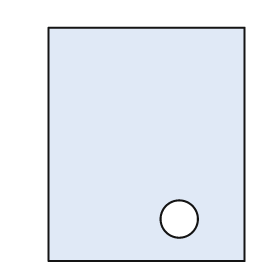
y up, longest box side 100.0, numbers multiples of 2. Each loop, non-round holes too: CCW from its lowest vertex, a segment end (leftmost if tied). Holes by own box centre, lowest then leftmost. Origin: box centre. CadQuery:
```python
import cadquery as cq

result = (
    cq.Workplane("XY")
    .moveTo(-42.0, -50.0)
    .lineTo(42.0, -50.0)
    .lineTo(42.0, 50.0)
    .lineTo(-42.0, 50.0)
    .close()
    .moveTo(14.0, -32.0)
    .circle(8.0)
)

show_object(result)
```